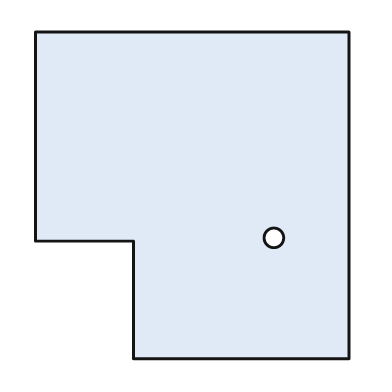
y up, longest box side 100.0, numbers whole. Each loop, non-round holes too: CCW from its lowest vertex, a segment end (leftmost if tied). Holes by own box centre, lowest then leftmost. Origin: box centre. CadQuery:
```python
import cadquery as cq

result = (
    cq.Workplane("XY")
    .moveTo(-18.0, -50.0)
    .lineTo(48.0, -50.0)
    .lineTo(48.0, 50.0)
    .lineTo(-48.0, 50.0)
    .lineTo(-48.0, -14.0)
    .lineTo(-18.0, -14.0)
    .close()
    .moveTo(25.0, -13.0)
    .circle(3.0)
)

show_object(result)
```